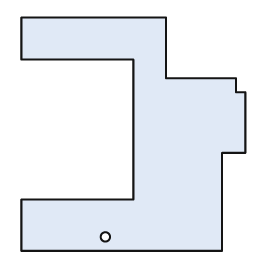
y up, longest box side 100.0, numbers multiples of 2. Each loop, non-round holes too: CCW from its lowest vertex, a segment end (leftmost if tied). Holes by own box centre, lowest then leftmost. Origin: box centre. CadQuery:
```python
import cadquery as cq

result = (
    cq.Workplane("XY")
    .moveTo(-48.0, -50.0)
    .lineTo(38.0, -50.0)
    .lineTo(38.0, -8.0)
    .lineTo(48.0, -8.0)
    .lineTo(48.0, 18.0)
    .lineTo(44.0, 18.0)
    .lineTo(44.0, 24.0)
    .lineTo(14.0, 24.0)
    .lineTo(14.0, 50.0)
    .lineTo(-48.0, 50.0)
    .lineTo(-48.0, 32.0)
    .lineTo(0.0, 32.0)
    .lineTo(0.0, -28.0)
    .lineTo(-48.0, -28.0)
    .close()
    .moveTo(-12.0, -44.0)
    .circle(2.0)
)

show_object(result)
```